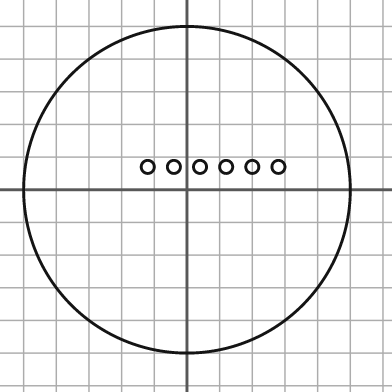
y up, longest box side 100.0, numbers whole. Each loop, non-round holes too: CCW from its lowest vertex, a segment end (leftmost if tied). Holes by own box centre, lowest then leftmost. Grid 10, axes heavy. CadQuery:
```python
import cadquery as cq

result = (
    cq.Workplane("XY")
    .moveTo(0.0, 0.0)
    .circle(50.0)
    .moveTo(-12.0, 7.0)
    .circle(2.0)
    .moveTo(-4.0, 7.0)
    .circle(2.0)
    .moveTo(4.0, 7.0)
    .circle(2.0)
    .moveTo(12.0, 7.0)
    .circle(2.0)
    .moveTo(20.0, 7.0)
    .circle(2.0)
    .moveTo(28.0, 7.0)
    .circle(2.0)
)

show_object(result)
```